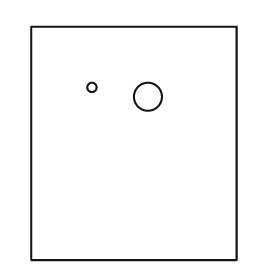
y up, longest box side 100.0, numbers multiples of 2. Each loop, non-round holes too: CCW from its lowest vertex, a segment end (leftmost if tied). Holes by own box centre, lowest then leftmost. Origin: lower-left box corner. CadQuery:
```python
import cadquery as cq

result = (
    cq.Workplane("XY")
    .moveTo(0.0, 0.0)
    .lineTo(88.0, 0.0)
    .lineTo(88.0, 100.0)
    .lineTo(0.0, 100.0)
    .close()
    .moveTo(50.0, 70.0)
    .circle(6.0)
    .moveTo(26.0, 74.0)
    .circle(2.0)
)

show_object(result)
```